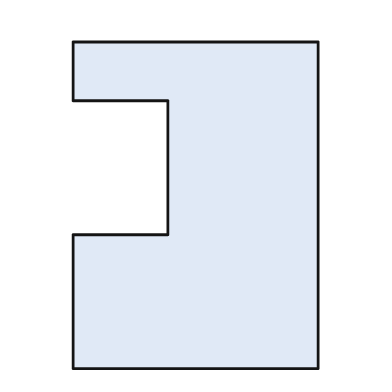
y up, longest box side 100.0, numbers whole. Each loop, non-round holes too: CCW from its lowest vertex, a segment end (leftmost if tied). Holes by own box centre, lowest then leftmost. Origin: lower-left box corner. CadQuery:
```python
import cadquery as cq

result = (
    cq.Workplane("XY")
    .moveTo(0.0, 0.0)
    .lineTo(75.0, 0.0)
    .lineTo(75.0, 100.0)
    .lineTo(0.0, 100.0)
    .lineTo(0.0, 82.0)
    .lineTo(29.0, 82.0)
    .lineTo(29.0, 41.0)
    .lineTo(0.0, 41.0)
    .close()
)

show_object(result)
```